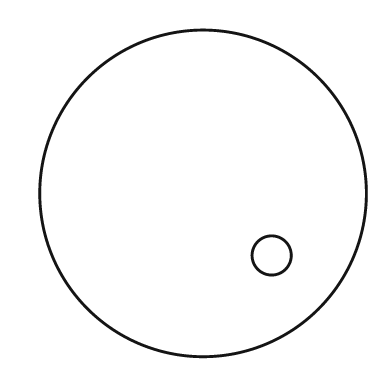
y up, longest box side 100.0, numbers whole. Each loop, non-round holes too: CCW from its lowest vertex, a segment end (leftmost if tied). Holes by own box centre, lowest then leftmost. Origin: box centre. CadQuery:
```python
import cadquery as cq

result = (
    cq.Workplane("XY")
    .moveTo(0.0, 0.0)
    .circle(50.0)
    .moveTo(21.0, -19.0)
    .circle(6.0)
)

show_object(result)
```